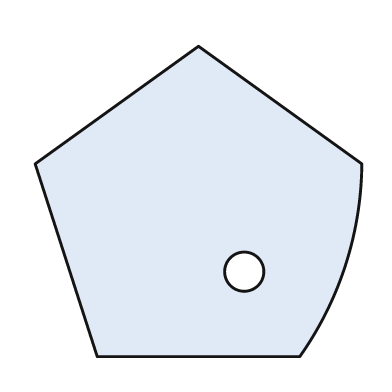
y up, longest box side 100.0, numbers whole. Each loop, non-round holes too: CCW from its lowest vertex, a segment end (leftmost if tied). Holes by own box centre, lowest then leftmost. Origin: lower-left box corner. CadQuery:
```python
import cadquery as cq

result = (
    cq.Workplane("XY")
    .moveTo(19.0, 0.0)
    .lineTo(81.0, 0.0)
    .threePointArc((95.0, 28.0), (100.0, 59.0))
    .lineTo(50.0, 95.0)
    .lineTo(0.0, 59.0)
    .close()
    .moveTo(64.0, 26.0)
    .circle(6.0)
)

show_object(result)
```